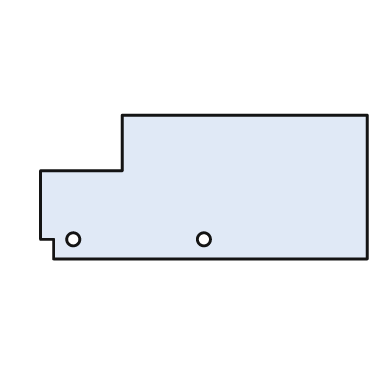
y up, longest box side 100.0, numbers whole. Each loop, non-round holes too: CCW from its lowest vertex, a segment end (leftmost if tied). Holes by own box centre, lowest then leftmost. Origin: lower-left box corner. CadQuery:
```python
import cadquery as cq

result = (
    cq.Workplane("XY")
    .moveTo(4.0, 0.0)
    .lineTo(100.0, 0.0)
    .lineTo(100.0, 44.0)
    .lineTo(25.0, 44.0)
    .lineTo(25.0, 27.0)
    .lineTo(0.0, 27.0)
    .lineTo(0.0, 6.0)
    .lineTo(4.0, 6.0)
    .close()
    .moveTo(10.0, 6.0)
    .circle(2.0)
    .moveTo(50.0, 6.0)
    .circle(2.0)
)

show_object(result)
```